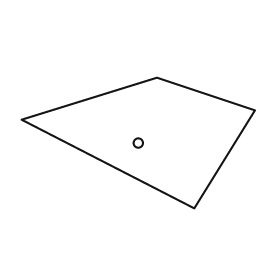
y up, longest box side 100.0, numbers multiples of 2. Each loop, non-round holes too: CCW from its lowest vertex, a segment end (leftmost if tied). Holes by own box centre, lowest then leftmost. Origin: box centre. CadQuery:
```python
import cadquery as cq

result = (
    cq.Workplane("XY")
    .moveTo(24.0, -28.0)
    .lineTo(50.0, 14.0)
    .lineTo(8.0, 28.0)
    .lineTo(-50.0, 10.0)
    .close()
    .moveTo(0.0, 0.0)
    .circle(2.0)
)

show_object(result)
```